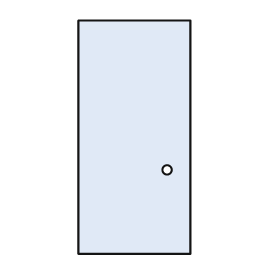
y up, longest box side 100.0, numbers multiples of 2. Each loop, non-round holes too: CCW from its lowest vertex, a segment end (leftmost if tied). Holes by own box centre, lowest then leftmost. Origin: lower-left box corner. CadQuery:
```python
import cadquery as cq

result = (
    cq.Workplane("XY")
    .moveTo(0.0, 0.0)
    .lineTo(48.0, 0.0)
    .lineTo(48.0, 100.0)
    .lineTo(0.0, 100.0)
    .close()
    .moveTo(38.0, 36.0)
    .circle(2.0)
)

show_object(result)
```